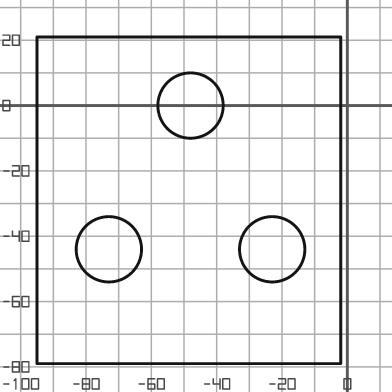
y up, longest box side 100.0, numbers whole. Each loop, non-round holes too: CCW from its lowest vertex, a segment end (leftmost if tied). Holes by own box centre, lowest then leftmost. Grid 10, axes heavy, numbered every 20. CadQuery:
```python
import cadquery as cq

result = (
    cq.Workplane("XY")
    .moveTo(-95.0, -79.0)
    .lineTo(-2.0, -79.0)
    .lineTo(-2.0, 21.0)
    .lineTo(-95.0, 21.0)
    .close()
    .moveTo(-73.0, -44.0)
    .circle(10.0)
    .moveTo(-23.0, -44.0)
    .circle(10.0)
    .moveTo(-48.0, 0.0)
    .circle(10.0)
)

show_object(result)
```